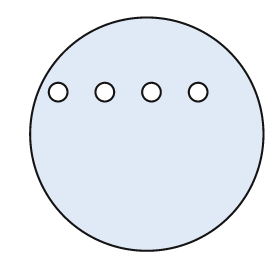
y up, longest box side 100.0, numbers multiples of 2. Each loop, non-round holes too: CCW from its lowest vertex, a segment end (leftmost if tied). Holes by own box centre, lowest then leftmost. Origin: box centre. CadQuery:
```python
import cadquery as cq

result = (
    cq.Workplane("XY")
    .moveTo(0.0, 0.0)
    .circle(50.0)
    .moveTo(-38.0, 18.0)
    .circle(4.0)
    .moveTo(-18.0, 18.0)
    .circle(4.0)
    .moveTo(2.0, 18.0)
    .circle(4.0)
    .moveTo(22.0, 18.0)
    .circle(4.0)
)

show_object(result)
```